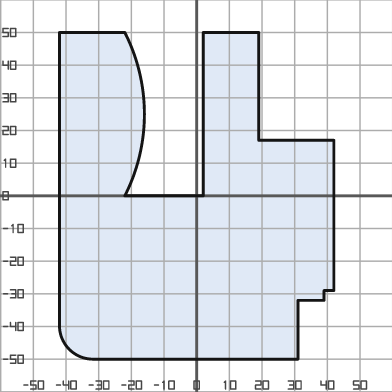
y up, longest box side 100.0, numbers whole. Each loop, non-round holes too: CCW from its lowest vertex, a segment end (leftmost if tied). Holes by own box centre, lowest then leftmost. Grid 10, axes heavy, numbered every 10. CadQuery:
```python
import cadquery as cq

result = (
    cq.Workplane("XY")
    .moveTo(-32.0, -50.0)
    .lineTo(31.0, -50.0)
    .lineTo(31.0, -32.0)
    .lineTo(39.0, -32.0)
    .lineTo(39.0, -29.0)
    .lineTo(42.0, -29.0)
    .lineTo(42.0, 17.0)
    .lineTo(19.0, 17.0)
    .lineTo(19.0, 50.0)
    .lineTo(2.0, 50.0)
    .lineTo(2.0, 0.0)
    .lineTo(-22.0, 0.0)
    .threePointArc((-16.0, 25.0), (-22.0, 50.0))
    .lineTo(-42.0, 50.0)
    .lineTo(-42.0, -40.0)
    .threePointArc((-39.0, -47.0), (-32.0, -50.0))
    .close()
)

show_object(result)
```